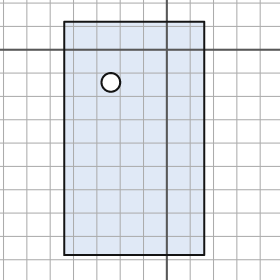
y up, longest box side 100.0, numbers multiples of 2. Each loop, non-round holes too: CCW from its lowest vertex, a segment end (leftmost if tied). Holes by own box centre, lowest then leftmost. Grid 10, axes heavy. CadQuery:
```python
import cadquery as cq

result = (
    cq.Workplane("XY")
    .moveTo(-44.0, -88.0)
    .lineTo(16.0, -88.0)
    .lineTo(16.0, 12.0)
    .lineTo(-44.0, 12.0)
    .close()
    .moveTo(-24.0, -14.0)
    .circle(4.0)
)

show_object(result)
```